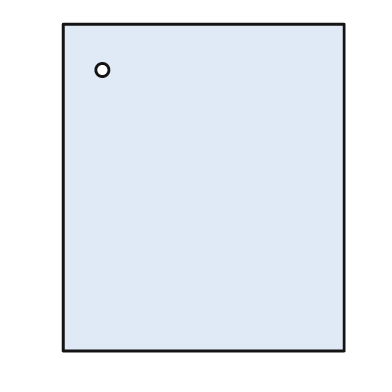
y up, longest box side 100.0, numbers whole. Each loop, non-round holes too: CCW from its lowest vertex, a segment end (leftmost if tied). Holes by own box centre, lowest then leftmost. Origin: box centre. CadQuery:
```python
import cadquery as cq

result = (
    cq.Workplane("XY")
    .moveTo(-43.0, -50.0)
    .lineTo(43.0, -50.0)
    .lineTo(43.0, 50.0)
    .lineTo(-43.0, 50.0)
    .close()
    .moveTo(-31.0, 36.0)
    .circle(2.0)
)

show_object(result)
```